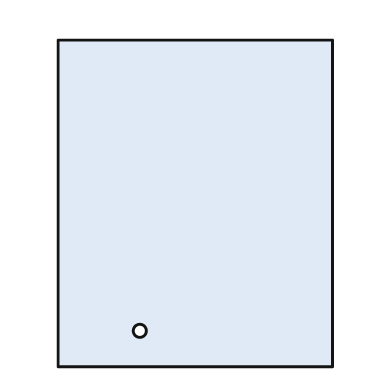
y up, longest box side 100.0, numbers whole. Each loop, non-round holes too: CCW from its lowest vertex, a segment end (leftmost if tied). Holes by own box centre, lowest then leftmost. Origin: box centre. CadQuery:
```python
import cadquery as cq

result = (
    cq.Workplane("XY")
    .moveTo(-42.0, -50.0)
    .lineTo(42.0, -50.0)
    .lineTo(42.0, 50.0)
    .lineTo(-42.0, 50.0)
    .close()
    .moveTo(-17.0, -39.0)
    .circle(2.0)
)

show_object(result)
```